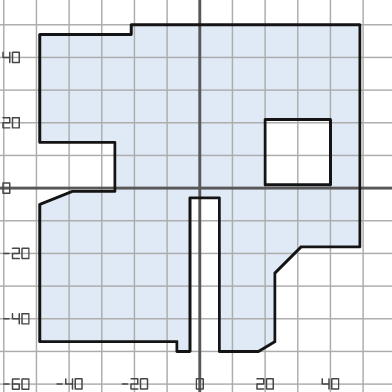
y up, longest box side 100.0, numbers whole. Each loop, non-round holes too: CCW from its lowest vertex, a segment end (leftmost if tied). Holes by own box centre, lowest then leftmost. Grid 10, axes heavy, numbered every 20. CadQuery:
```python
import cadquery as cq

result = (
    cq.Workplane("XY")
    .moveTo(-7.0, -50.0)
    .lineTo(-3.0, -50.0)
    .lineTo(-3.0, -3.0)
    .lineTo(6.0, -3.0)
    .lineTo(6.0, -50.0)
    .lineTo(18.0, -50.0)
    .lineTo(23.0, -47.0)
    .lineTo(23.0, -26.0)
    .lineTo(31.0, -18.0)
    .lineTo(49.0, -18.0)
    .lineTo(49.0, 50.0)
    .lineTo(-21.0, 50.0)
    .lineTo(-21.0, 47.0)
    .lineTo(-49.0, 47.0)
    .lineTo(-49.0, 14.0)
    .lineTo(-26.0, 14.0)
    .lineTo(-26.0, -1.0)
    .lineTo(-39.0, -1.0)
    .lineTo(-49.0, -5.0)
    .lineTo(-49.0, -47.0)
    .lineTo(-7.0, -47.0)
    .close()
    .moveTo(20.0, 1.0)
    .lineTo(40.0, 1.0)
    .lineTo(40.0, 21.0)
    .lineTo(20.0, 21.0)
    .close()
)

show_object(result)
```